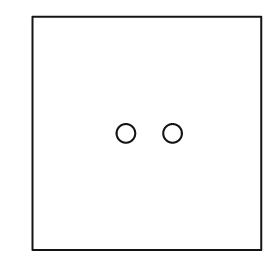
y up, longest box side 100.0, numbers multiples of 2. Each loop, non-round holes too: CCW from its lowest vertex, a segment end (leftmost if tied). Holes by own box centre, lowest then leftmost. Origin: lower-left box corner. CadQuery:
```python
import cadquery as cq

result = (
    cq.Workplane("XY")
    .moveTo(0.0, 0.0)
    .lineTo(98.0, 0.0)
    .lineTo(98.0, 100.0)
    .lineTo(0.0, 100.0)
    .close()
    .moveTo(40.0, 50.0)
    .circle(4.0)
    .moveTo(60.0, 50.0)
    .circle(4.0)
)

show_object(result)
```